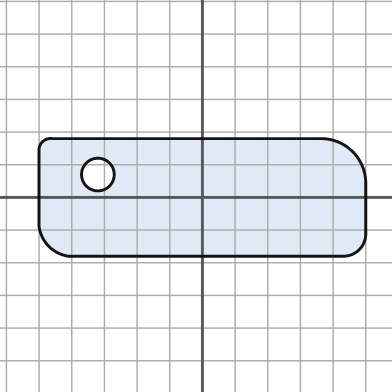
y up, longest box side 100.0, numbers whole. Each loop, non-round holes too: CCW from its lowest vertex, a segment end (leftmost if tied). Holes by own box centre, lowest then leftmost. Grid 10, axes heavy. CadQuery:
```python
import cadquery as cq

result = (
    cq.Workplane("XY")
    .moveTo(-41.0, -18.0)
    .lineTo(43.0, -18.0)
    .threePointArc((48.0, -16.0), (50.0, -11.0))
    .lineTo(50.0, 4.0)
    .threePointArc((46.0, 14.0), (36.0, 18.0))
    .lineTo(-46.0, 18.0)
    .threePointArc((-49.0, 17.0), (-50.0, 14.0))
    .lineTo(-50.0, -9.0)
    .threePointArc((-47.0, -15.0), (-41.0, -18.0))
    .close()
    .moveTo(-32.0, 7.0)
    .circle(5.0)
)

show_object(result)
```